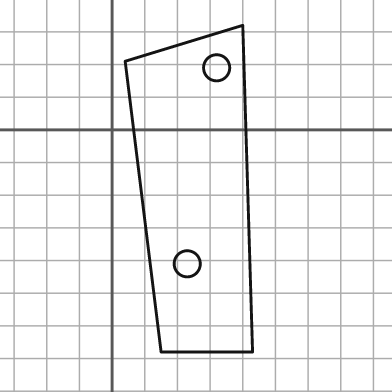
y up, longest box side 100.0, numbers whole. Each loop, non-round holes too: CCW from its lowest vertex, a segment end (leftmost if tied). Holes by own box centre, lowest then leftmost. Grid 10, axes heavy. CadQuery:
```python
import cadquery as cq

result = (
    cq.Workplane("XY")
    .moveTo(15.0, -68.0)
    .lineTo(43.0, -68.0)
    .lineTo(40.0, 32.0)
    .lineTo(4.0, 21.0)
    .close()
    .moveTo(23.0, -41.0)
    .circle(4.0)
    .moveTo(32.0, 19.0)
    .circle(4.0)
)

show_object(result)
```